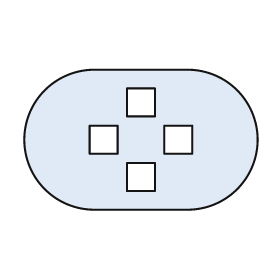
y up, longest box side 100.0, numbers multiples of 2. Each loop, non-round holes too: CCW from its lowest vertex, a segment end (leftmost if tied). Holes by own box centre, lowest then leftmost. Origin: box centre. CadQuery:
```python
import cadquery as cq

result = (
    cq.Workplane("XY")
    .moveTo(-20.0, -30.0)
    .lineTo(20.0, -30.0)
    .threePointArc((50.0, 0.0), (20.0, 30.0))
    .lineTo(-20.0, 30.0)
    .threePointArc((-50.0, 0.0), (-20.0, -30.0))
    .close()
    .moveTo(-6.0, -22.0)
    .lineTo(6.0, -22.0)
    .lineTo(6.0, -10.0)
    .lineTo(-6.0, -10.0)
    .close()
    .moveTo(-22.0, -6.0)
    .lineTo(-10.0, -6.0)
    .lineTo(-10.0, 6.0)
    .lineTo(-22.0, 6.0)
    .close()
    .moveTo(10.0, -6.0)
    .lineTo(22.0, -6.0)
    .lineTo(22.0, 6.0)
    .lineTo(10.0, 6.0)
    .close()
    .moveTo(-6.0, 10.0)
    .lineTo(6.0, 10.0)
    .lineTo(6.0, 22.0)
    .lineTo(-6.0, 22.0)
    .close()
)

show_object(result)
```